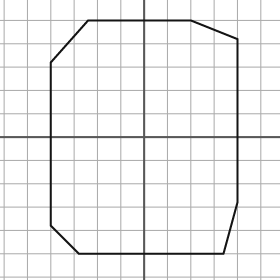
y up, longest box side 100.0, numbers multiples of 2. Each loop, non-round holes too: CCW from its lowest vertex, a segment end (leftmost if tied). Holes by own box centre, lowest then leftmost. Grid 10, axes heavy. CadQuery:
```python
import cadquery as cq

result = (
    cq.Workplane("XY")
    .moveTo(-28.0, -50.0)
    .lineTo(34.0, -50.0)
    .lineTo(40.0, -28.0)
    .lineTo(40.0, 42.0)
    .lineTo(20.0, 50.0)
    .lineTo(-24.0, 50.0)
    .lineTo(-40.0, 32.0)
    .lineTo(-40.0, -38.0)
    .close()
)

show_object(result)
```